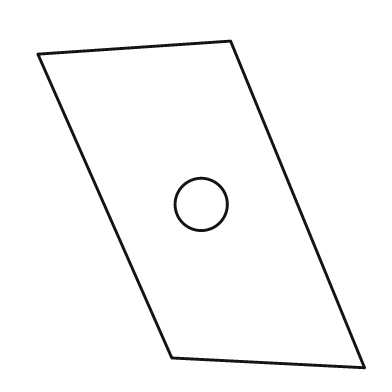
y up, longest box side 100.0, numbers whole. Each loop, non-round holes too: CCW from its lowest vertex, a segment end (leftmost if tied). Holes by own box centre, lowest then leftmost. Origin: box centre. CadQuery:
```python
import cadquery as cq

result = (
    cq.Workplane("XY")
    .moveTo(50.0, -50.0)
    .lineTo(9.0, 50.0)
    .lineTo(-50.0, 46.0)
    .lineTo(-9.0, -47.0)
    .close()
    .moveTo(0.0, 0.0)
    .circle(8.0)
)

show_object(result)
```